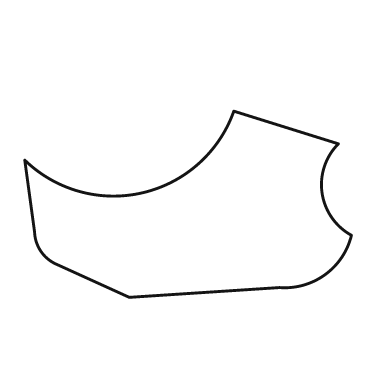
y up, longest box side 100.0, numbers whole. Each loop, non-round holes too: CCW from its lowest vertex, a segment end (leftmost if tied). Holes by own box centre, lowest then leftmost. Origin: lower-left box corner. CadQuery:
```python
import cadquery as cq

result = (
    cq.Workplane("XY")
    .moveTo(32.0, 0.0)
    .lineTo(78.0, 3.0)
    .threePointArc((92.0, 7.0), (100.0, 19.0))
    .threePointArc((91.0, 32.0), (96.0, 47.0))
    .lineTo(64.0, 57.0)
    .threePointArc((36.0, 32.0), (0.0, 42.0))
    .lineTo(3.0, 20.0)
    .threePointArc((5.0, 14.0), (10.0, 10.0))
    .close()
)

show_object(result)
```